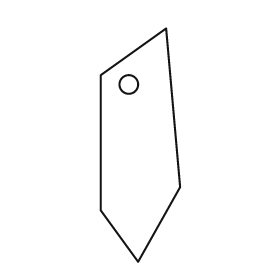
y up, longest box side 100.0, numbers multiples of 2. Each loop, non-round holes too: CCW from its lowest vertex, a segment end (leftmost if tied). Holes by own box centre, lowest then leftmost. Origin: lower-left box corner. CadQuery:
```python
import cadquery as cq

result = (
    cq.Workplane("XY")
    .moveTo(16.0, 0.0)
    .lineTo(34.0, 32.0)
    .lineTo(28.0, 100.0)
    .lineTo(0.0, 80.0)
    .lineTo(0.0, 22.0)
    .close()
    .moveTo(12.0, 76.0)
    .circle(4.0)
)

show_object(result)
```